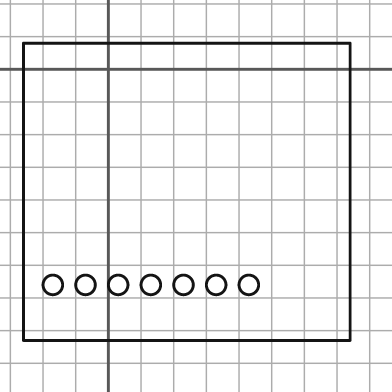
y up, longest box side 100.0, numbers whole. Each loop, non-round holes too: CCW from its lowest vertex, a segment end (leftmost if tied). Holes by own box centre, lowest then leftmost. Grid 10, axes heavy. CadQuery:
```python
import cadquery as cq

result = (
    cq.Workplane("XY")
    .moveTo(-26.0, -83.0)
    .lineTo(74.0, -83.0)
    .lineTo(74.0, 8.0)
    .lineTo(-26.0, 8.0)
    .close()
    .moveTo(-17.0, -66.0)
    .circle(3.0)
    .moveTo(-7.0, -66.0)
    .circle(3.0)
    .moveTo(3.0, -66.0)
    .circle(3.0)
    .moveTo(13.0, -66.0)
    .circle(3.0)
    .moveTo(23.0, -66.0)
    .circle(3.0)
    .moveTo(33.0, -66.0)
    .circle(3.0)
    .moveTo(43.0, -66.0)
    .circle(3.0)
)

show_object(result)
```